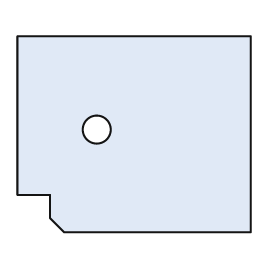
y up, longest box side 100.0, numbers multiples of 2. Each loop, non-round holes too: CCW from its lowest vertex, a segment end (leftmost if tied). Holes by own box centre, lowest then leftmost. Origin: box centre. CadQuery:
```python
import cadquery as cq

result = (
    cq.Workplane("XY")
    .moveTo(-30.0, -42.0)
    .lineTo(50.0, -42.0)
    .lineTo(50.0, 42.0)
    .lineTo(-50.0, 42.0)
    .lineTo(-50.0, -26.0)
    .lineTo(-36.0, -26.0)
    .lineTo(-36.0, -36.0)
    .close()
    .moveTo(-16.0, 2.0)
    .circle(6.0)
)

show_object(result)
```